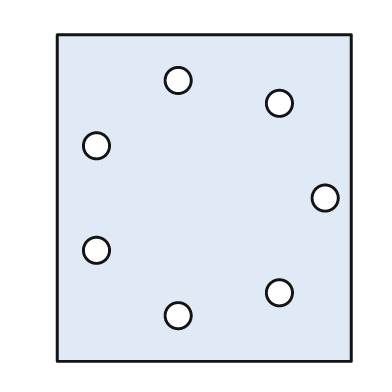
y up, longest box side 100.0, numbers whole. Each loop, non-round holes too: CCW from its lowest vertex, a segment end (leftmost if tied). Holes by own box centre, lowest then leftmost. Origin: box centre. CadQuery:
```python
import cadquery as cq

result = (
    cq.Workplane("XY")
    .moveTo(-45.0, -50.0)
    .lineTo(45.0, -50.0)
    .lineTo(45.0, 50.0)
    .lineTo(-45.0, 50.0)
    .close()
    .moveTo(-8.0, -36.0)
    .circle(4.0)
    .moveTo(23.0, -29.0)
    .circle(4.0)
    .moveTo(-33.0, -16.0)
    .circle(4.0)
    .moveTo(37.0, 0.0)
    .circle(4.0)
    .moveTo(-33.0, 16.0)
    .circle(4.0)
    .moveTo(23.0, 29.0)
    .circle(4.0)
    .moveTo(-8.0, 36.0)
    .circle(4.0)
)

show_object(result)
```